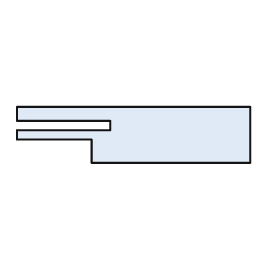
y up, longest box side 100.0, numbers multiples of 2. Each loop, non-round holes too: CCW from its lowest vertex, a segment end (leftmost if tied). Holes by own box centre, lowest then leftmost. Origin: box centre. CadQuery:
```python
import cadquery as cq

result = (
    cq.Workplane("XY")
    .moveTo(-18.0, -12.0)
    .lineTo(50.0, -12.0)
    .lineTo(50.0, 12.0)
    .lineTo(-50.0, 12.0)
    .lineTo(-50.0, 6.0)
    .lineTo(-10.0, 6.0)
    .lineTo(-10.0, 2.0)
    .lineTo(-50.0, 2.0)
    .lineTo(-50.0, -2.0)
    .lineTo(-18.0, -2.0)
    .close()
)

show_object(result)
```